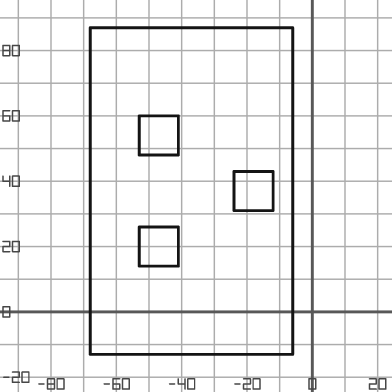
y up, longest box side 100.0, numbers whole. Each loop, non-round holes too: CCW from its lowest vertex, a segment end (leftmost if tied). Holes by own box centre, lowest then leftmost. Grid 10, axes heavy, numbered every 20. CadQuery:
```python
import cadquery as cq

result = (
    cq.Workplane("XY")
    .moveTo(-68.0, -13.0)
    .lineTo(-6.0, -13.0)
    .lineTo(-6.0, 87.0)
    .lineTo(-68.0, 87.0)
    .close()
    .moveTo(-53.0, 14.0)
    .lineTo(-41.0, 14.0)
    .lineTo(-41.0, 26.0)
    .lineTo(-53.0, 26.0)
    .close()
    .moveTo(-24.0, 31.0)
    .lineTo(-12.0, 31.0)
    .lineTo(-12.0, 43.0)
    .lineTo(-24.0, 43.0)
    .close()
    .moveTo(-53.0, 48.0)
    .lineTo(-41.0, 48.0)
    .lineTo(-41.0, 60.0)
    .lineTo(-53.0, 60.0)
    .close()
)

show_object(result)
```